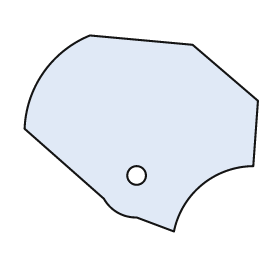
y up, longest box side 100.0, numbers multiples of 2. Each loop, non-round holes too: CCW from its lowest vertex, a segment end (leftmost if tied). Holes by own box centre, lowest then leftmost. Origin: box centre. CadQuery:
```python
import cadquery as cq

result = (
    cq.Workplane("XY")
    .moveTo(14.0, -42.0)
    .threePointArc((26.0, -22.0), (48.0, -14.0))
    .lineTo(50.0, 14.0)
    .lineTo(22.0, 38.0)
    .lineTo(-22.0, 42.0)
    .threePointArc((-42.0, 26.0), (-50.0, 2.0))
    .lineTo(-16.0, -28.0)
    .threePointArc((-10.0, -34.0), (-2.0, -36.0))
    .close()
    .moveTo(-2.0, -18.0)
    .circle(4.0)
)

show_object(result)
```